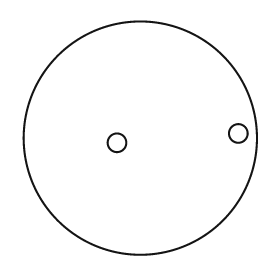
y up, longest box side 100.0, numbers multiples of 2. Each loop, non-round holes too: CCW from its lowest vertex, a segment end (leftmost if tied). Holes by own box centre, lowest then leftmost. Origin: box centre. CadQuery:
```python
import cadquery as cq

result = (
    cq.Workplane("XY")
    .moveTo(0.0, 0.0)
    .circle(50.0)
    .moveTo(-10.0, -2.0)
    .circle(4.0)
    .moveTo(42.0, 2.0)
    .circle(4.0)
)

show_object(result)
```